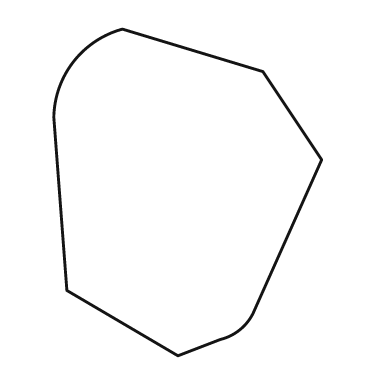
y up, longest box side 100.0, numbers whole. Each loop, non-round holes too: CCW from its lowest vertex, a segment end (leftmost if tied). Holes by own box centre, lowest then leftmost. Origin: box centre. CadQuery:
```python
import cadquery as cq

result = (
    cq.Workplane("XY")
    .moveTo(-3.0, -50.0)
    .lineTo(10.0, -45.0)
    .threePointArc((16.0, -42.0), (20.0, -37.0))
    .lineTo(41.0, 10.0)
    .lineTo(23.0, 37.0)
    .lineTo(-20.0, 50.0)
    .threePointArc((-35.0, 40.0), (-41.0, 23.0))
    .lineTo(-37.0, -30.0)
    .close()
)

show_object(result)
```